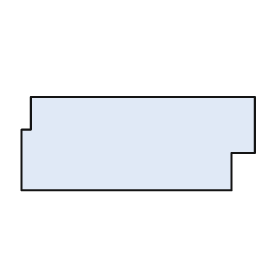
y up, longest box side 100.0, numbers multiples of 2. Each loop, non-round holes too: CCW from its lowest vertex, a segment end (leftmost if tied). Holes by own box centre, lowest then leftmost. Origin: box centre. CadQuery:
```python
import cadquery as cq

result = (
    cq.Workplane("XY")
    .moveTo(-50.0, -20.0)
    .lineTo(40.0, -20.0)
    .lineTo(40.0, -4.0)
    .lineTo(50.0, -4.0)
    .lineTo(50.0, 20.0)
    .lineTo(-46.0, 20.0)
    .lineTo(-46.0, 6.0)
    .lineTo(-50.0, 6.0)
    .close()
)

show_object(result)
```